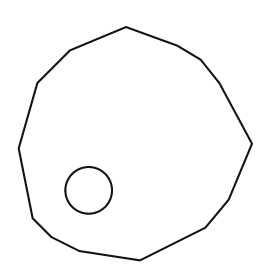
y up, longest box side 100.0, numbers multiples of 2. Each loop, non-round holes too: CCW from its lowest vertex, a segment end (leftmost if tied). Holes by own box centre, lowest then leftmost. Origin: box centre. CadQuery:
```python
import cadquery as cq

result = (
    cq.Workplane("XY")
    .moveTo(2.0, -50.0)
    .lineTo(30.0, -36.0)
    .lineTo(40.0, -24.0)
    .lineTo(50.0, 0.0)
    .lineTo(36.0, 26.0)
    .lineTo(28.0, 36.0)
    .lineTo(18.0, 42.0)
    .lineTo(-4.0, 50.0)
    .lineTo(-28.0, 40.0)
    .lineTo(-42.0, 26.0)
    .lineTo(-50.0, -2.0)
    .lineTo(-44.0, -32.0)
    .lineTo(-36.0, -40.0)
    .lineTo(-24.0, -46.0)
    .close()
    .moveTo(-20.0, -20.0)
    .circle(10.0)
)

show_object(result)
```